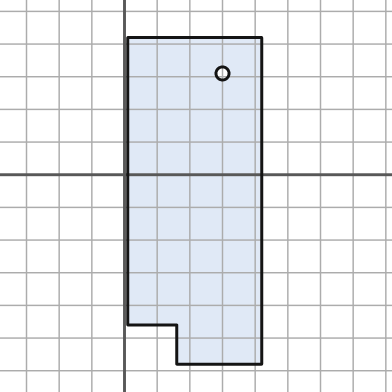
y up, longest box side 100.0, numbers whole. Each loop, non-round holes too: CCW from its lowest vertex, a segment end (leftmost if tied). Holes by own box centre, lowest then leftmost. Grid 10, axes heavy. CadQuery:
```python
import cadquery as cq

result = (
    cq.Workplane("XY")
    .moveTo(16.0, -58.0)
    .lineTo(42.0, -58.0)
    .lineTo(42.0, 42.0)
    .lineTo(1.0, 42.0)
    .lineTo(1.0, -46.0)
    .lineTo(16.0, -46.0)
    .close()
    .moveTo(30.0, 31.0)
    .circle(2.0)
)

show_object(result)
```